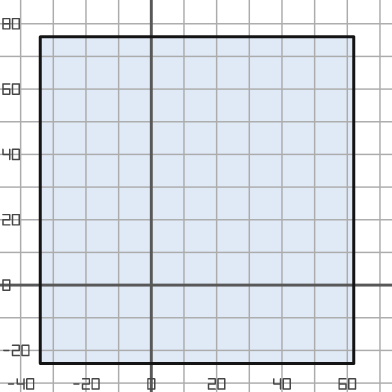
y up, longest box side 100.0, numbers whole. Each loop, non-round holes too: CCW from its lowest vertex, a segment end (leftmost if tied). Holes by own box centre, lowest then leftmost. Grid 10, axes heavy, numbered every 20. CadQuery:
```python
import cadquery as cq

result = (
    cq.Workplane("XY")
    .moveTo(-34.0, -24.0)
    .lineTo(62.0, -24.0)
    .lineTo(62.0, 76.0)
    .lineTo(-34.0, 76.0)
    .close()
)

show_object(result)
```